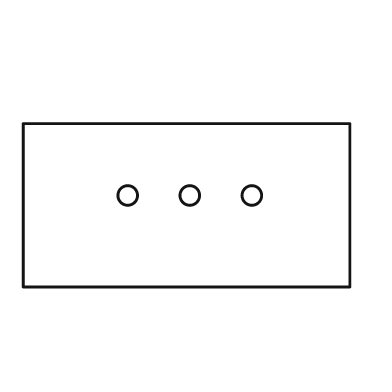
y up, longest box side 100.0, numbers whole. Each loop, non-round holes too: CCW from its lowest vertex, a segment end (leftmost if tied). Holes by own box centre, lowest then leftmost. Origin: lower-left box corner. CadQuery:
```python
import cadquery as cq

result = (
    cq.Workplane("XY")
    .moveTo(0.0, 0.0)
    .lineTo(100.0, 0.0)
    .lineTo(100.0, 50.0)
    .lineTo(0.0, 50.0)
    .close()
    .moveTo(32.0, 28.0)
    .circle(3.0)
    .moveTo(51.0, 28.0)
    .circle(3.0)
    .moveTo(70.0, 28.0)
    .circle(3.0)
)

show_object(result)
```